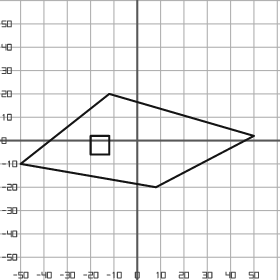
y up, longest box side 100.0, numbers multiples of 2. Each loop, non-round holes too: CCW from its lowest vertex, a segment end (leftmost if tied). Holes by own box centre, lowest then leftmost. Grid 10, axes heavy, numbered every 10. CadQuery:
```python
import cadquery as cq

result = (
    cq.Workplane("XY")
    .moveTo(8.0, -20.0)
    .lineTo(50.0, 2.0)
    .lineTo(-12.0, 20.0)
    .lineTo(-50.0, -10.0)
    .close()
    .moveTo(-20.0, -6.0)
    .lineTo(-12.0, -6.0)
    .lineTo(-12.0, 2.0)
    .lineTo(-20.0, 2.0)
    .close()
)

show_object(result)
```